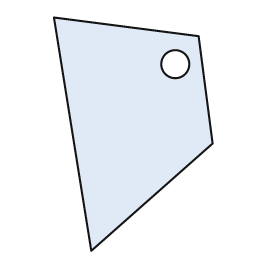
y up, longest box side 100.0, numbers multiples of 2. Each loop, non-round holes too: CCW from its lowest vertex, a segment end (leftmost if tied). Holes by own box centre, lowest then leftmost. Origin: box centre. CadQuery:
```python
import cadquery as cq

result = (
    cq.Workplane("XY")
    .moveTo(-18.0, -50.0)
    .lineTo(34.0, -4.0)
    .lineTo(28.0, 42.0)
    .lineTo(-34.0, 50.0)
    .close()
    .moveTo(18.0, 30.0)
    .circle(6.0)
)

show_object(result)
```